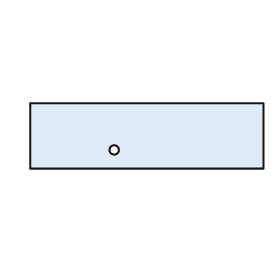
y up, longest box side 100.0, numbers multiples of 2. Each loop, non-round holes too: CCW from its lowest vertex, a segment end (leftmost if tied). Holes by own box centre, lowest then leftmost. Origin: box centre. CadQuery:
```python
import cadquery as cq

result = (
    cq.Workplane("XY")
    .moveTo(-50.0, -14.0)
    .lineTo(50.0, -14.0)
    .lineTo(50.0, 14.0)
    .lineTo(-50.0, 14.0)
    .close()
    .moveTo(-14.0, -6.0)
    .circle(2.0)
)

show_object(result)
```